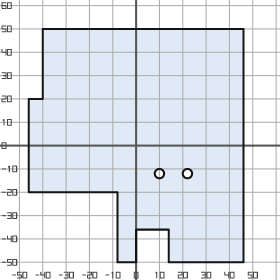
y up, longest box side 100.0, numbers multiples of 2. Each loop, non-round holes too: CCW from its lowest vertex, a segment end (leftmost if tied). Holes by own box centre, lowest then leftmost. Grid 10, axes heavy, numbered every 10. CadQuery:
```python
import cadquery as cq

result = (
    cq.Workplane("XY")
    .moveTo(-8.0, -50.0)
    .lineTo(0.0, -50.0)
    .lineTo(0.0, -36.0)
    .lineTo(14.0, -36.0)
    .lineTo(14.0, -50.0)
    .lineTo(46.0, -50.0)
    .lineTo(46.0, 50.0)
    .lineTo(-40.0, 50.0)
    .lineTo(-40.0, 20.0)
    .lineTo(-46.0, 20.0)
    .lineTo(-46.0, -20.0)
    .lineTo(-8.0, -20.0)
    .close()
    .moveTo(10.0, -12.0)
    .circle(2.0)
    .moveTo(22.0, -12.0)
    .circle(2.0)
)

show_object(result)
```